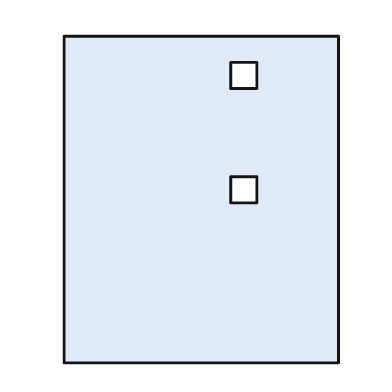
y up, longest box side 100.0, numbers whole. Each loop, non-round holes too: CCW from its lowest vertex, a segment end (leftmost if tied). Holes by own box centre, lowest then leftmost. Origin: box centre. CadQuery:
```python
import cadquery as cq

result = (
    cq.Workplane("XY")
    .moveTo(-42.0, -50.0)
    .lineTo(42.0, -50.0)
    .lineTo(42.0, 50.0)
    .lineTo(-42.0, 50.0)
    .close()
    .moveTo(9.0, -1.0)
    .lineTo(17.0, -1.0)
    .lineTo(17.0, 7.0)
    .lineTo(9.0, 7.0)
    .close()
    .moveTo(9.0, 34.0)
    .lineTo(17.0, 34.0)
    .lineTo(17.0, 42.0)
    .lineTo(9.0, 42.0)
    .close()
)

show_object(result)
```